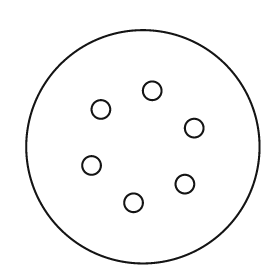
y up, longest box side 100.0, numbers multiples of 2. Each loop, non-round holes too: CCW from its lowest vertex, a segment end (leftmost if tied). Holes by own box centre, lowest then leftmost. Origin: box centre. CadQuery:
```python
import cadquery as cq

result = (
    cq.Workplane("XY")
    .moveTo(0.0, 0.0)
    .circle(50.0)
    .moveTo(-4.0, -24.0)
    .circle(4.0)
    .moveTo(18.0, -16.0)
    .circle(4.0)
    .moveTo(-22.0, -8.0)
    .circle(4.0)
    .moveTo(22.0, 8.0)
    .circle(4.0)
    .moveTo(-18.0, 16.0)
    .circle(4.0)
    .moveTo(4.0, 24.0)
    .circle(4.0)
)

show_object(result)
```